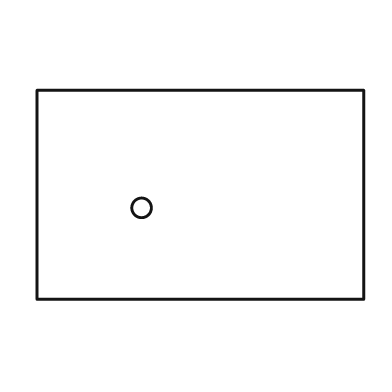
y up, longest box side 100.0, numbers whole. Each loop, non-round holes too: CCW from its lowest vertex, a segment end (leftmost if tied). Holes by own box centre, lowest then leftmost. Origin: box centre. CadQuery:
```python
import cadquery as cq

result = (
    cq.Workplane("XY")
    .moveTo(-50.0, -32.0)
    .lineTo(50.0, -32.0)
    .lineTo(50.0, 32.0)
    .lineTo(-50.0, 32.0)
    .close()
    .moveTo(-18.0, -4.0)
    .circle(3.0)
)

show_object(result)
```